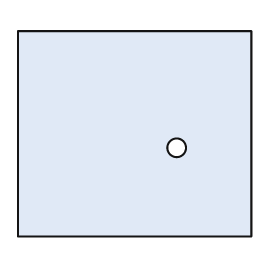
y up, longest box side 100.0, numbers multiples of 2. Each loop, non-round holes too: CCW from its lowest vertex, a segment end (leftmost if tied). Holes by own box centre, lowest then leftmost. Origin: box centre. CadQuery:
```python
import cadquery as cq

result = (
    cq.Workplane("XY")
    .moveTo(-50.0, -44.0)
    .lineTo(50.0, -44.0)
    .lineTo(50.0, 44.0)
    .lineTo(-50.0, 44.0)
    .close()
    .moveTo(18.0, -6.0)
    .circle(4.0)
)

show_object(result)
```